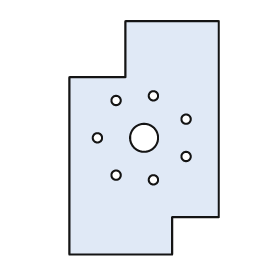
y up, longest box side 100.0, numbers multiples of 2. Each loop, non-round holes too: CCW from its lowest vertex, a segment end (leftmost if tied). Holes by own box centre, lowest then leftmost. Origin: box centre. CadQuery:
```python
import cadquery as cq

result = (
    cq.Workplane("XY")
    .moveTo(-32.0, -50.0)
    .lineTo(12.0, -50.0)
    .lineTo(12.0, -34.0)
    .lineTo(32.0, -34.0)
    .lineTo(32.0, 50.0)
    .lineTo(-8.0, 50.0)
    .lineTo(-8.0, 26.0)
    .lineTo(-32.0, 26.0)
    .close()
    .moveTo(4.0, -18.0)
    .circle(2.0)
    .moveTo(-12.0, -16.0)
    .circle(2.0)
    .moveTo(18.0, -8.0)
    .circle(2.0)
    .moveTo(-20.0, 0.0)
    .circle(2.0)
    .moveTo(0.0, 0.0)
    .circle(6.0)
    .moveTo(18.0, 8.0)
    .circle(2.0)
    .moveTo(-12.0, 16.0)
    .circle(2.0)
    .moveTo(4.0, 18.0)
    .circle(2.0)
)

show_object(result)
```